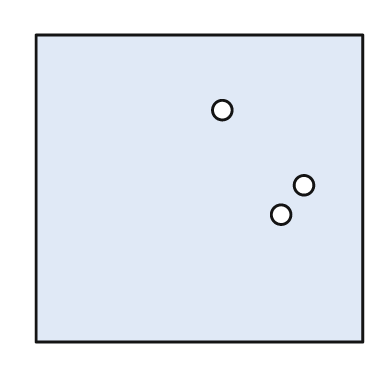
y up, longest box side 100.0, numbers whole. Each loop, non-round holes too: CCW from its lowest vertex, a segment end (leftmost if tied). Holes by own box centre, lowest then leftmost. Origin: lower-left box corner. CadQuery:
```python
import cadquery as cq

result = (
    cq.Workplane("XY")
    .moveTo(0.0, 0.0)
    .lineTo(100.0, 0.0)
    .lineTo(100.0, 94.0)
    .lineTo(0.0, 94.0)
    .close()
    .moveTo(75.0, 39.0)
    .circle(3.0)
    .moveTo(82.0, 48.0)
    .circle(3.0)
    .moveTo(57.0, 71.0)
    .circle(3.0)
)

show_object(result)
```